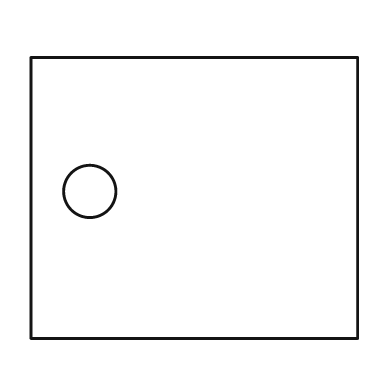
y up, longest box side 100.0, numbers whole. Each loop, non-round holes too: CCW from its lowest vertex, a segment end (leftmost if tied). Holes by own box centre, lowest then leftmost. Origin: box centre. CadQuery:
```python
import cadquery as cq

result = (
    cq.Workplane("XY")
    .moveTo(-50.0, -43.0)
    .lineTo(50.0, -43.0)
    .lineTo(50.0, 43.0)
    .lineTo(-50.0, 43.0)
    .close()
    .moveTo(-32.0, 2.0)
    .circle(8.0)
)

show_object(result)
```